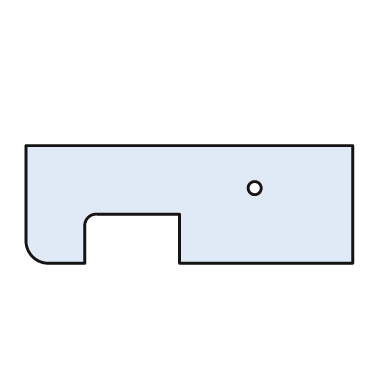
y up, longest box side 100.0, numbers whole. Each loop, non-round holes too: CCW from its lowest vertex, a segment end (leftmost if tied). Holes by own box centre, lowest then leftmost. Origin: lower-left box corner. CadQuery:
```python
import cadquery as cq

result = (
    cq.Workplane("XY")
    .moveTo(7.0, 0.0)
    .lineTo(18.0, 0.0)
    .lineTo(18.0, 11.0)
    .threePointArc((19.0, 14.0), (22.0, 15.0))
    .lineTo(47.0, 15.0)
    .lineTo(47.0, 0.0)
    .lineTo(100.0, 0.0)
    .lineTo(100.0, 36.0)
    .lineTo(0.0, 36.0)
    .lineTo(0.0, 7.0)
    .threePointArc((2.0, 2.0), (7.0, 0.0))
    .close()
    .moveTo(70.0, 23.0)
    .circle(2.0)
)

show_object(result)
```